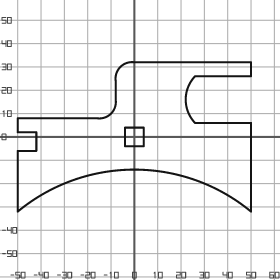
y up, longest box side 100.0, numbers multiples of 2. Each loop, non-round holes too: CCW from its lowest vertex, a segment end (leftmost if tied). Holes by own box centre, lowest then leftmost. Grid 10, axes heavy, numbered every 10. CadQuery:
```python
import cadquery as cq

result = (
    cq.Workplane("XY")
    .moveTo(-50.0, -32.0)
    .threePointArc((0.0, -14.0), (50.0, -32.0))
    .lineTo(50.0, 6.0)
    .lineTo(26.0, 6.0)
    .threePointArc((22.0, 16.0), (26.0, 26.0))
    .lineTo(50.0, 26.0)
    .lineTo(50.0, 32.0)
    .lineTo(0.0, 32.0)
    .threePointArc((-6.0, 30.0), (-8.0, 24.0))
    .lineTo(-8.0, 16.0)
    .threePointArc((-10.0, 10.0), (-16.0, 8.0))
    .lineTo(-50.0, 8.0)
    .lineTo(-50.0, 2.0)
    .lineTo(-42.0, 2.0)
    .lineTo(-42.0, -6.0)
    .lineTo(-50.0, -6.0)
    .close()
    .moveTo(-4.0, -4.0)
    .lineTo(4.0, -4.0)
    .lineTo(4.0, 4.0)
    .lineTo(-4.0, 4.0)
    .close()
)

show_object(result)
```